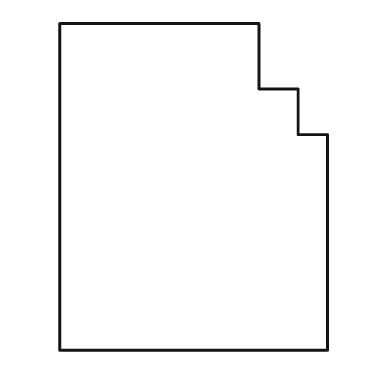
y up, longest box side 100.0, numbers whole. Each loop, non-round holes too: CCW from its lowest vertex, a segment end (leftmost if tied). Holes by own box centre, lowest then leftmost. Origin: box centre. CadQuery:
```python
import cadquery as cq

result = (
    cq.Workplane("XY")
    .moveTo(-41.0, -50.0)
    .lineTo(41.0, -50.0)
    .lineTo(41.0, 16.0)
    .lineTo(32.0, 16.0)
    .lineTo(32.0, 30.0)
    .lineTo(20.0, 30.0)
    .lineTo(20.0, 50.0)
    .lineTo(-41.0, 50.0)
    .close()
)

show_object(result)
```